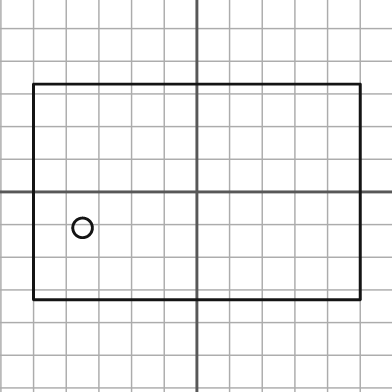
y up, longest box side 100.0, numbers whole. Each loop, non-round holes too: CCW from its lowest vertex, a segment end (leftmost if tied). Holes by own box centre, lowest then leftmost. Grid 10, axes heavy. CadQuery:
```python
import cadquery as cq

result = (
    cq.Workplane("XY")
    .moveTo(-50.0, -33.0)
    .lineTo(50.0, -33.0)
    .lineTo(50.0, 33.0)
    .lineTo(-50.0, 33.0)
    .close()
    .moveTo(-35.0, -11.0)
    .circle(3.0)
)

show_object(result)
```